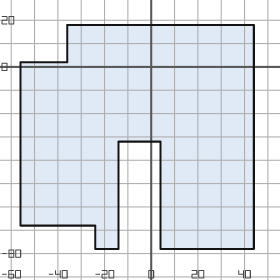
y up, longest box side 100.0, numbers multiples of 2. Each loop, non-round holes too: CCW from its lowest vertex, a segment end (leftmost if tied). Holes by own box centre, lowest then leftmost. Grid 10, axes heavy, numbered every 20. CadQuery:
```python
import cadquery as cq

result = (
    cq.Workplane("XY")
    .moveTo(-24.0, -78.0)
    .lineTo(-14.0, -78.0)
    .lineTo(-14.0, -32.0)
    .lineTo(4.0, -32.0)
    .lineTo(4.0, -78.0)
    .lineTo(44.0, -78.0)
    .lineTo(44.0, 18.0)
    .lineTo(-36.0, 18.0)
    .lineTo(-36.0, 2.0)
    .lineTo(-56.0, 2.0)
    .lineTo(-56.0, -68.0)
    .lineTo(-24.0, -68.0)
    .close()
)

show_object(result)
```